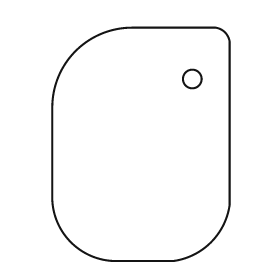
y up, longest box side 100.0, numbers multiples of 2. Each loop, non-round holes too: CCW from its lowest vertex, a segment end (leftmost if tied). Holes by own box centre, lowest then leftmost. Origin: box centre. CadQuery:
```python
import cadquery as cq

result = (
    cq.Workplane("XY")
    .moveTo(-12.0, -50.0)
    .lineTo(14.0, -50.0)
    .threePointArc((30.0, -42.0), (38.0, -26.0))
    .lineTo(38.0, 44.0)
    .threePointArc((36.0, 48.0), (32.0, 50.0))
    .lineTo(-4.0, 50.0)
    .threePointArc((-28.0, 40.0), (-38.0, 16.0))
    .lineTo(-38.0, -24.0)
    .threePointArc((-30.0, -42.0), (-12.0, -50.0))
    .close()
    .moveTo(22.0, 28.0)
    .circle(4.0)
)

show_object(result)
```